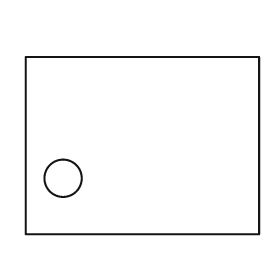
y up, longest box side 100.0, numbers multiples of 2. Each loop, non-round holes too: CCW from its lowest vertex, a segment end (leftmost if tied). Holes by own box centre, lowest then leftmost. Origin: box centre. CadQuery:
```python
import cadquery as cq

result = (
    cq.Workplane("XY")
    .moveTo(-50.0, -38.0)
    .lineTo(50.0, -38.0)
    .lineTo(50.0, 38.0)
    .lineTo(-50.0, 38.0)
    .close()
    .moveTo(-34.0, -14.0)
    .circle(8.0)
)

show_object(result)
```